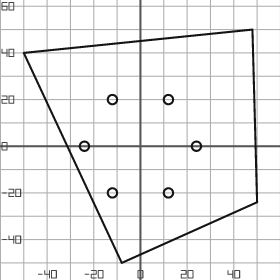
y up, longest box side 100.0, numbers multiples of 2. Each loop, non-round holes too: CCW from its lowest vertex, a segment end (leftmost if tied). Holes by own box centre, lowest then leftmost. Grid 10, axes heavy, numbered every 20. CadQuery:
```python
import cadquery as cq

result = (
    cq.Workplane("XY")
    .moveTo(-8.0, -50.0)
    .lineTo(50.0, -24.0)
    .lineTo(48.0, 50.0)
    .lineTo(-50.0, 40.0)
    .close()
    .moveTo(-12.0, -20.0)
    .circle(2.0)
    .moveTo(12.0, -20.0)
    .circle(2.0)
    .moveTo(-24.0, 0.0)
    .circle(2.0)
    .moveTo(24.0, 0.0)
    .circle(2.0)
    .moveTo(-12.0, 20.0)
    .circle(2.0)
    .moveTo(12.0, 20.0)
    .circle(2.0)
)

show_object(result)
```